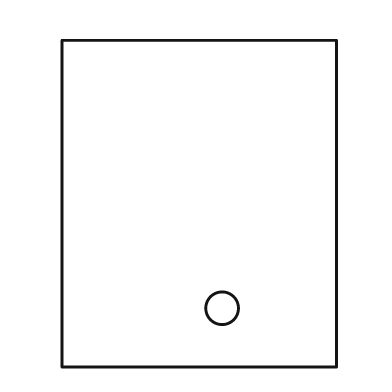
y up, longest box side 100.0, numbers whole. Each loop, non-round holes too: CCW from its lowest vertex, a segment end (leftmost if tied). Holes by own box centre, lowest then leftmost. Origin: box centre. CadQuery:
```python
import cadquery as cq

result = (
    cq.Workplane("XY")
    .moveTo(-42.0, -50.0)
    .lineTo(42.0, -50.0)
    .lineTo(42.0, 50.0)
    .lineTo(-42.0, 50.0)
    .close()
    .moveTo(7.0, -32.0)
    .circle(5.0)
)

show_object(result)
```